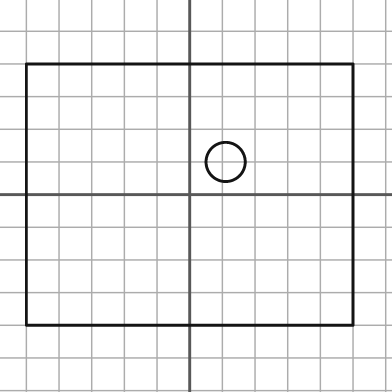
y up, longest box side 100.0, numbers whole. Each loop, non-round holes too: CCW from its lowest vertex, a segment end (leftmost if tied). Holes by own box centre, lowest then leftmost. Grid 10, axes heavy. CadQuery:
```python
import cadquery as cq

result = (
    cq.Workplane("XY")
    .moveTo(-50.0, -40.0)
    .lineTo(50.0, -40.0)
    .lineTo(50.0, 40.0)
    .lineTo(-50.0, 40.0)
    .close()
    .moveTo(11.0, 10.0)
    .circle(6.0)
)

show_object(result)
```